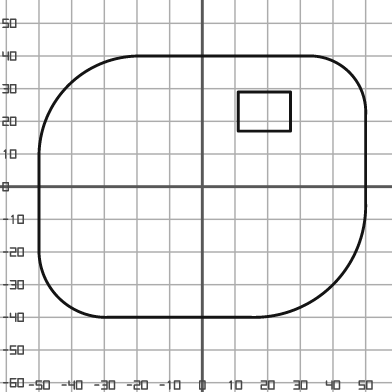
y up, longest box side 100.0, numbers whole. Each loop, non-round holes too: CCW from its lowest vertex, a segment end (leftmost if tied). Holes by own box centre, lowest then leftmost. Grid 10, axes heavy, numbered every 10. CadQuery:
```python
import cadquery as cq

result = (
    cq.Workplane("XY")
    .moveTo(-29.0, -40.0)
    .lineTo(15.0, -40.0)
    .threePointArc((40.0, -30.0), (50.0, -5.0))
    .lineTo(50.0, 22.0)
    .threePointArc((45.0, 35.0), (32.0, 40.0))
    .lineTo(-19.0, 40.0)
    .threePointArc((-41.0, 31.0), (-50.0, 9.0))
    .lineTo(-50.0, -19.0)
    .threePointArc((-44.0, -34.0), (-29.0, -40.0))
    .close()
    .moveTo(11.0, 17.0)
    .lineTo(27.0, 17.0)
    .lineTo(27.0, 29.0)
    .lineTo(11.0, 29.0)
    .close()
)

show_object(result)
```